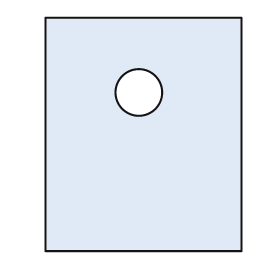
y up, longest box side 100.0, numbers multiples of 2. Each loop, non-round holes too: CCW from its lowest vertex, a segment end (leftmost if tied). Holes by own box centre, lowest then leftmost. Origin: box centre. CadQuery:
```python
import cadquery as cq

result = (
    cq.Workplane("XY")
    .moveTo(-42.0, -50.0)
    .lineTo(42.0, -50.0)
    .lineTo(42.0, 50.0)
    .lineTo(-42.0, 50.0)
    .close()
    .moveTo(-2.0, 18.0)
    .circle(10.0)
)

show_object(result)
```